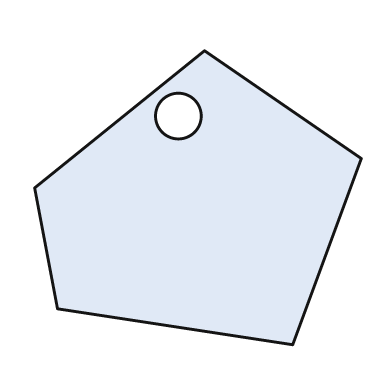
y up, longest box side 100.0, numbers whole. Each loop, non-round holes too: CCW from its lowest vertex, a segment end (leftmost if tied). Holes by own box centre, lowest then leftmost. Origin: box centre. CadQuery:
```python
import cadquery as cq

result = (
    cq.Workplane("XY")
    .moveTo(29.0, -45.0)
    .lineTo(50.0, 12.0)
    .lineTo(2.0, 45.0)
    .lineTo(-50.0, 3.0)
    .lineTo(-43.0, -34.0)
    .close()
    .moveTo(-6.0, 25.0)
    .circle(7.0)
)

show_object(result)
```